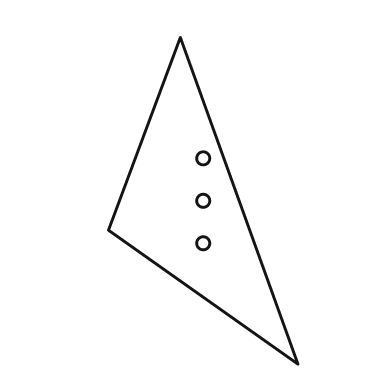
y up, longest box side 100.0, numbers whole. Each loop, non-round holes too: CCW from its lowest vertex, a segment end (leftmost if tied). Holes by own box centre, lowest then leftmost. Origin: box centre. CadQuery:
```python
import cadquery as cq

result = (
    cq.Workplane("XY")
    .moveTo(29.0, -50.0)
    .lineTo(-7.0, 50.0)
    .lineTo(-29.0, -9.0)
    .close()
    .moveTo(0.0, -13.0)
    .circle(2.0)
    .moveTo(0.0, 0.0)
    .circle(2.0)
    .moveTo(0.0, 13.0)
    .circle(2.0)
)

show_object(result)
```